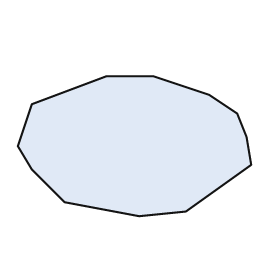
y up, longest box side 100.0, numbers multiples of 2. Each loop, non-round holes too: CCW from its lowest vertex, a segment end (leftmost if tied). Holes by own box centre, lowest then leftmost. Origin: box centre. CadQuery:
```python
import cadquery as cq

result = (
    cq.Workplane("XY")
    .moveTo(2.0, -30.0)
    .lineTo(22.0, -28.0)
    .lineTo(50.0, -8.0)
    .lineTo(48.0, 4.0)
    .lineTo(44.0, 14.0)
    .lineTo(32.0, 22.0)
    .lineTo(8.0, 30.0)
    .lineTo(-12.0, 30.0)
    .lineTo(-44.0, 18.0)
    .lineTo(-50.0, 0.0)
    .lineTo(-44.0, -10.0)
    .lineTo(-30.0, -24.0)
    .close()
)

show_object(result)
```